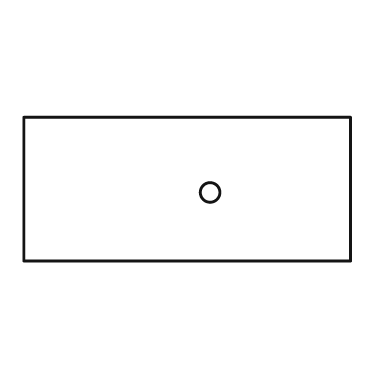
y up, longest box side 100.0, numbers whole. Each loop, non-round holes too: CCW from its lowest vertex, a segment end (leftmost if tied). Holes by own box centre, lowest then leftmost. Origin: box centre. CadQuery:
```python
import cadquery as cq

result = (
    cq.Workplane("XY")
    .moveTo(-50.0, -22.0)
    .lineTo(50.0, -22.0)
    .lineTo(50.0, 22.0)
    .lineTo(-50.0, 22.0)
    .close()
    .moveTo(7.0, -1.0)
    .circle(3.0)
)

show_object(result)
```